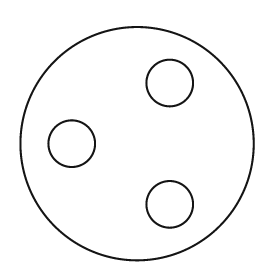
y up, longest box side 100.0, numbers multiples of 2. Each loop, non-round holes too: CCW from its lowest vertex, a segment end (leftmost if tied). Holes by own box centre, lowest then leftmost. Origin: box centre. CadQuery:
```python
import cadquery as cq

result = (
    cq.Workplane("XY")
    .moveTo(0.0, 0.0)
    .circle(50.0)
    .moveTo(14.0, -26.0)
    .circle(10.0)
    .moveTo(-28.0, 0.0)
    .circle(10.0)
    .moveTo(14.0, 26.0)
    .circle(10.0)
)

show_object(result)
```